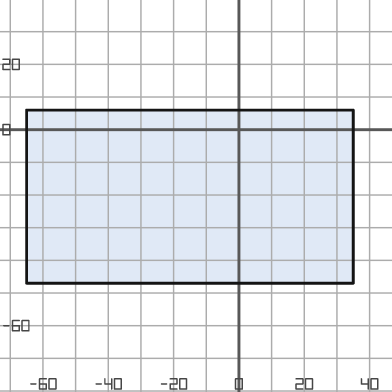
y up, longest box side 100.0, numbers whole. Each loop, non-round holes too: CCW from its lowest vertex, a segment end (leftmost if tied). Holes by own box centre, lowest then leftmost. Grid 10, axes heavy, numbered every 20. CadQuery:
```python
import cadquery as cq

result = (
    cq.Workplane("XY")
    .moveTo(-65.0, -47.0)
    .lineTo(35.0, -47.0)
    .lineTo(35.0, 6.0)
    .lineTo(-65.0, 6.0)
    .close()
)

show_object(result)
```